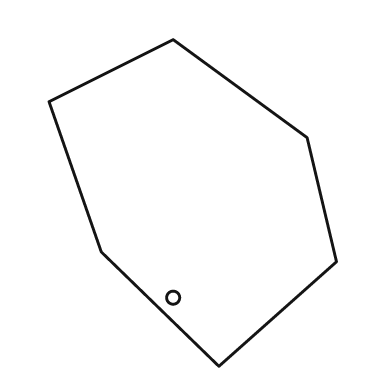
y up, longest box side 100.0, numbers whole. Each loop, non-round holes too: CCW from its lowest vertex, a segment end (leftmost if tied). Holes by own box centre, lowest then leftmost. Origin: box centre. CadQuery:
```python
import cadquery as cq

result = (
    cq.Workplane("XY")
    .moveTo(8.0, -50.0)
    .lineTo(44.0, -18.0)
    .lineTo(35.0, 20.0)
    .lineTo(-6.0, 50.0)
    .lineTo(-44.0, 31.0)
    .lineTo(-28.0, -15.0)
    .close()
    .moveTo(-6.0, -29.0)
    .circle(2.0)
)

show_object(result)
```